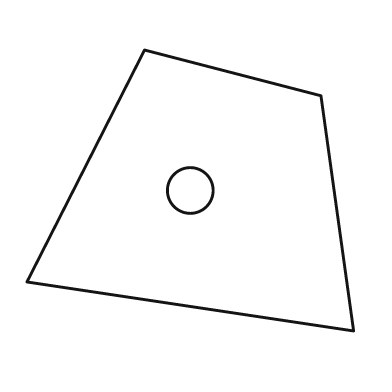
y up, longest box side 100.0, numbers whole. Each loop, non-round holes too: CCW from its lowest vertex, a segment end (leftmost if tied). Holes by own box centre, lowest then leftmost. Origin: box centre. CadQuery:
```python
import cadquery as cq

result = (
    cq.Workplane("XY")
    .moveTo(50.0, -43.0)
    .lineTo(40.0, 29.0)
    .lineTo(-14.0, 43.0)
    .lineTo(-50.0, -28.0)
    .close()
    .moveTo(0.0, 0.0)
    .circle(7.0)
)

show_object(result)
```